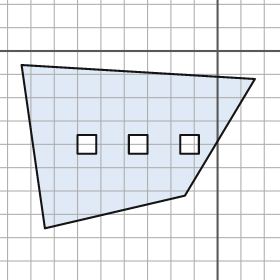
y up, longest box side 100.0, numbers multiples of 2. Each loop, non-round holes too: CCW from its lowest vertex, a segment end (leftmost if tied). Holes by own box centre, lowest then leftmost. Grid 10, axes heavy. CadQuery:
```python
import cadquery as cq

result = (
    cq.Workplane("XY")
    .moveTo(-74.0, -76.0)
    .lineTo(-14.0, -62.0)
    .lineTo(16.0, -12.0)
    .lineTo(-84.0, -6.0)
    .close()
    .moveTo(-60.0, -44.0)
    .lineTo(-52.0, -44.0)
    .lineTo(-52.0, -36.0)
    .lineTo(-60.0, -36.0)
    .close()
    .moveTo(-38.0, -44.0)
    .lineTo(-30.0, -44.0)
    .lineTo(-30.0, -36.0)
    .lineTo(-38.0, -36.0)
    .close()
    .moveTo(-16.0, -44.0)
    .lineTo(-8.0, -44.0)
    .lineTo(-8.0, -36.0)
    .lineTo(-16.0, -36.0)
    .close()
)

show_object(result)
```